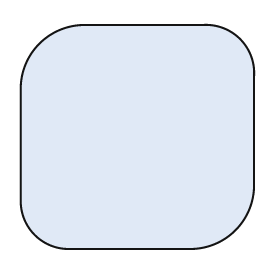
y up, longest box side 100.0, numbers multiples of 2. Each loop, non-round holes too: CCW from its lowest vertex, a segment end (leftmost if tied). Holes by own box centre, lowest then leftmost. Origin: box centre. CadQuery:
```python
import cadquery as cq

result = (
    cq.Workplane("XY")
    .moveTo(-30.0, -48.0)
    .lineTo(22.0, -48.0)
    .threePointArc((42.0, -40.0), (50.0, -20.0))
    .lineTo(50.0, 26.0)
    .threePointArc((44.0, 42.0), (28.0, 48.0))
    .lineTo(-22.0, 48.0)
    .threePointArc((-42.0, 40.0), (-50.0, 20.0))
    .lineTo(-50.0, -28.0)
    .threePointArc((-44.0, -42.0), (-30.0, -48.0))
    .close()
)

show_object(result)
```